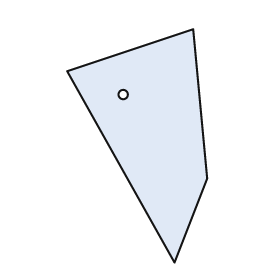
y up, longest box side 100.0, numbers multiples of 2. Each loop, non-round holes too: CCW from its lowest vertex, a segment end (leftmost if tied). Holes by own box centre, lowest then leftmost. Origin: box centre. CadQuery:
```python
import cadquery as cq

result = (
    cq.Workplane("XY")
    .moveTo(16.0, -50.0)
    .lineTo(30.0, -14.0)
    .lineTo(24.0, 50.0)
    .lineTo(-30.0, 32.0)
    .close()
    .moveTo(-6.0, 22.0)
    .circle(2.0)
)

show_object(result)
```